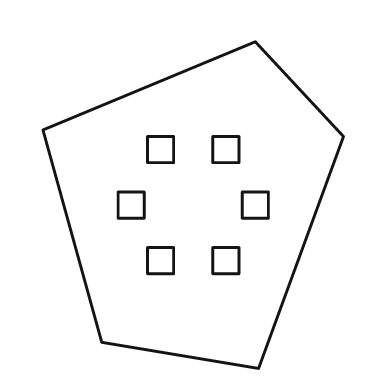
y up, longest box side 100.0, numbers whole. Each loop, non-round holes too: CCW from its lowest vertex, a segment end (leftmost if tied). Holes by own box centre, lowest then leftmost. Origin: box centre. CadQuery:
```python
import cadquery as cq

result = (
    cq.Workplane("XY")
    .moveTo(20.0, -50.0)
    .lineTo(46.0, 21.0)
    .lineTo(19.0, 50.0)
    .lineTo(-46.0, 23.0)
    .lineTo(-28.0, -42.0)
    .close()
    .moveTo(-14.0, -21.0)
    .lineTo(-6.0, -21.0)
    .lineTo(-6.0, -13.0)
    .lineTo(-14.0, -13.0)
    .close()
    .moveTo(6.0, -21.0)
    .lineTo(14.0, -21.0)
    .lineTo(14.0, -13.0)
    .lineTo(6.0, -13.0)
    .close()
    .moveTo(-23.0, -4.0)
    .lineTo(-15.0, -4.0)
    .lineTo(-15.0, 4.0)
    .lineTo(-23.0, 4.0)
    .close()
    .moveTo(15.0, -4.0)
    .lineTo(23.0, -4.0)
    .lineTo(23.0, 4.0)
    .lineTo(15.0, 4.0)
    .close()
    .moveTo(-14.0, 13.0)
    .lineTo(-6.0, 13.0)
    .lineTo(-6.0, 21.0)
    .lineTo(-14.0, 21.0)
    .close()
    .moveTo(6.0, 13.0)
    .lineTo(14.0, 13.0)
    .lineTo(14.0, 21.0)
    .lineTo(6.0, 21.0)
    .close()
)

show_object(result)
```